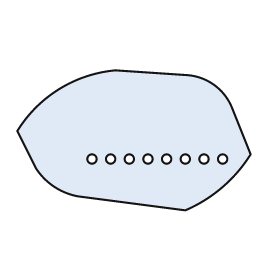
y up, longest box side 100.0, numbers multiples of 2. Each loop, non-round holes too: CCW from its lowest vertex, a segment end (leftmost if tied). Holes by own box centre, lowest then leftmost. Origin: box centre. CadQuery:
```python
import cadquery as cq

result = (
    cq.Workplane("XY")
    .moveTo(22.0, -30.0)
    .threePointArc((38.0, -20.0), (50.0, -6.0))
    .lineTo(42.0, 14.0)
    .threePointArc((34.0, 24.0), (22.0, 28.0))
    .lineTo(-8.0, 30.0)
    .threePointArc((-32.0, 22.0), (-50.0, 4.0))
    .lineTo(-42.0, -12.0)
    .threePointArc((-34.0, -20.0), (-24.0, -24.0))
    .close()
    .moveTo(-18.0, -8.0)
    .circle(2.0)
    .moveTo(-10.0, -8.0)
    .circle(2.0)
    .moveTo(-2.0, -8.0)
    .circle(2.0)
    .moveTo(6.0, -8.0)
    .circle(2.0)
    .moveTo(14.0, -8.0)
    .circle(2.0)
    .moveTo(22.0, -8.0)
    .circle(2.0)
    .moveTo(30.0, -8.0)
    .circle(2.0)
    .moveTo(38.0, -8.0)
    .circle(2.0)
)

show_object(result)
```